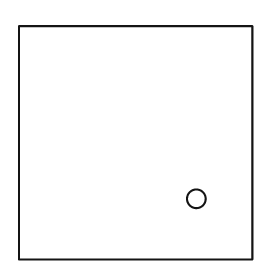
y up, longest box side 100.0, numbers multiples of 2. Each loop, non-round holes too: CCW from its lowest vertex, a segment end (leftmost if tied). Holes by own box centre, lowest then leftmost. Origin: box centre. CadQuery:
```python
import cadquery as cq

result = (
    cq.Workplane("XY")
    .moveTo(-50.0, -50.0)
    .lineTo(50.0, -50.0)
    .lineTo(50.0, 50.0)
    .lineTo(-50.0, 50.0)
    .close()
    .moveTo(26.0, -24.0)
    .circle(4.0)
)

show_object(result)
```